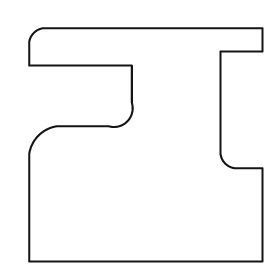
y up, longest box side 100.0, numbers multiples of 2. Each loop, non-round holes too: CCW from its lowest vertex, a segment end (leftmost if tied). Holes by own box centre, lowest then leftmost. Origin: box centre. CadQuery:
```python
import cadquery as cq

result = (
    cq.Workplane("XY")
    .moveTo(-50.0, -50.0)
    .lineTo(50.0, -50.0)
    .lineTo(50.0, -10.0)
    .lineTo(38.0, -10.0)
    .threePointArc((34.0, -8.0), (32.0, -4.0))
    .lineTo(32.0, 40.0)
    .lineTo(50.0, 40.0)
    .lineTo(50.0, 50.0)
    .lineTo(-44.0, 50.0)
    .threePointArc((-48.0, 48.0), (-50.0, 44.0))
    .lineTo(-50.0, 34.0)
    .lineTo(-6.0, 34.0)
    .lineTo(-6.0, 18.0)
    .threePointArc((-8.0, 10.0), (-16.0, 8.0))
    .lineTo(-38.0, 8.0)
    .threePointArc((-46.0, 4.0), (-50.0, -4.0))
    .close()
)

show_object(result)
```